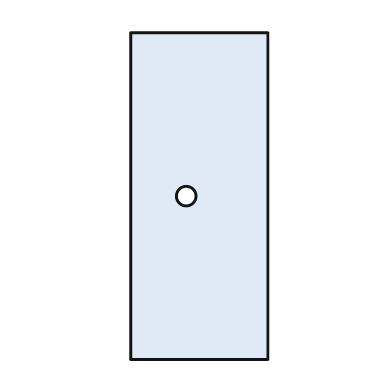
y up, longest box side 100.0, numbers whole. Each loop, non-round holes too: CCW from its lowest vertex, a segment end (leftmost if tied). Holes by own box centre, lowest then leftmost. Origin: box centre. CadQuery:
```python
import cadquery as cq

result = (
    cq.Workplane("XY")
    .moveTo(-21.0, -50.0)
    .lineTo(21.0, -50.0)
    .lineTo(21.0, 50.0)
    .lineTo(-21.0, 50.0)
    .close()
    .moveTo(-4.0, 0.0)
    .circle(3.0)
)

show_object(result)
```